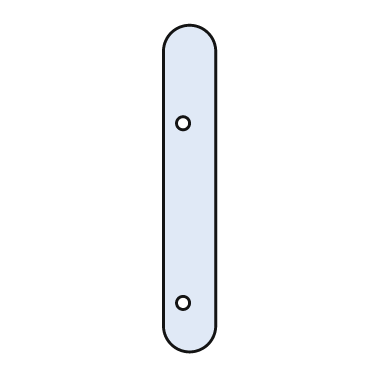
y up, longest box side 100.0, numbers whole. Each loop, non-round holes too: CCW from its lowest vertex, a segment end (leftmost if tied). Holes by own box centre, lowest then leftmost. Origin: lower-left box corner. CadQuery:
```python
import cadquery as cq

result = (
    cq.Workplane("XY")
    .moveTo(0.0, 8.0)
    .threePointArc((8.0, 0.0), (16.0, 8.0))
    .lineTo(16.0, 92.0)
    .threePointArc((8.0, 100.0), (0.0, 92.0))
    .close()
    .moveTo(6.0, 15.0)
    .circle(2.0)
    .moveTo(6.0, 70.0)
    .circle(2.0)
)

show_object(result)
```